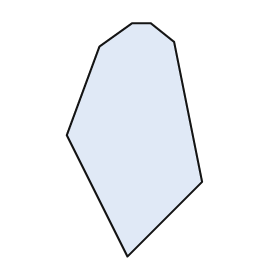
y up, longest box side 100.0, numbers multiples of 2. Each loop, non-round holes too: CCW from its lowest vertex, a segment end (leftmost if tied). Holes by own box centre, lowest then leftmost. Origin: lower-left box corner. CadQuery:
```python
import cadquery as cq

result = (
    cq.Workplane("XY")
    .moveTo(26.0, 0.0)
    .lineTo(58.0, 32.0)
    .lineTo(46.0, 92.0)
    .lineTo(36.0, 100.0)
    .lineTo(28.0, 100.0)
    .lineTo(14.0, 90.0)
    .lineTo(0.0, 52.0)
    .close()
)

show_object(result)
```